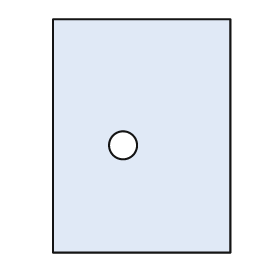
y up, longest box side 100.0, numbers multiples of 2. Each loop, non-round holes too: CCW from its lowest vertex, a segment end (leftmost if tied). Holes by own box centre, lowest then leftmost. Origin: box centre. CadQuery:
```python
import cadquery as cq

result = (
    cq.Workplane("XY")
    .moveTo(-38.0, -50.0)
    .lineTo(38.0, -50.0)
    .lineTo(38.0, 50.0)
    .lineTo(-38.0, 50.0)
    .close()
    .moveTo(-8.0, -4.0)
    .circle(6.0)
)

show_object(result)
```